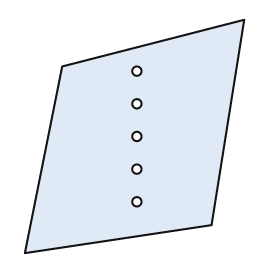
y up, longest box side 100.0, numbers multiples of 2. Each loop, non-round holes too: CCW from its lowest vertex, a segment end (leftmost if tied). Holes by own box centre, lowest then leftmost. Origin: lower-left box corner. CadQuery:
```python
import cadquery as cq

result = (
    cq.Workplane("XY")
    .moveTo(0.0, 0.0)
    .lineTo(80.0, 12.0)
    .lineTo(94.0, 100.0)
    .lineTo(16.0, 80.0)
    .close()
    .moveTo(48.0, 22.0)
    .circle(2.0)
    .moveTo(48.0, 36.0)
    .circle(2.0)
    .moveTo(48.0, 50.0)
    .circle(2.0)
    .moveTo(48.0, 64.0)
    .circle(2.0)
    .moveTo(48.0, 78.0)
    .circle(2.0)
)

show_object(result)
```